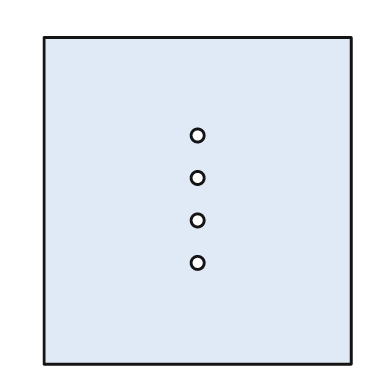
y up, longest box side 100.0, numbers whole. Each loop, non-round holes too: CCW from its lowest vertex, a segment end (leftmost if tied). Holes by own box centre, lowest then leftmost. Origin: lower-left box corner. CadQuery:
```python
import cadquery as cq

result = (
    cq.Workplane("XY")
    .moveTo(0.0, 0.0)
    .lineTo(94.0, 0.0)
    .lineTo(94.0, 100.0)
    .lineTo(0.0, 100.0)
    .close()
    .moveTo(47.0, 31.0)
    .circle(2.0)
    .moveTo(47.0, 44.0)
    .circle(2.0)
    .moveTo(47.0, 57.0)
    .circle(2.0)
    .moveTo(47.0, 70.0)
    .circle(2.0)
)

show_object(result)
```